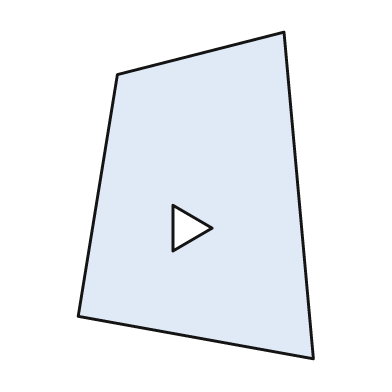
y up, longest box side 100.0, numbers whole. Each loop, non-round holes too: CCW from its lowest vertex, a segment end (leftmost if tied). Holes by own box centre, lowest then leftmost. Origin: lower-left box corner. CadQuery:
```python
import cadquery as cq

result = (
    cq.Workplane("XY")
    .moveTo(72.0, 0.0)
    .lineTo(63.0, 100.0)
    .lineTo(12.0, 87.0)
    .lineTo(0.0, 13.0)
    .close()
    .moveTo(29.0, 33.0)
    .lineTo(41.0, 40.0)
    .lineTo(29.0, 47.0)
    .close()
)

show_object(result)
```